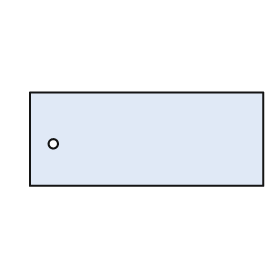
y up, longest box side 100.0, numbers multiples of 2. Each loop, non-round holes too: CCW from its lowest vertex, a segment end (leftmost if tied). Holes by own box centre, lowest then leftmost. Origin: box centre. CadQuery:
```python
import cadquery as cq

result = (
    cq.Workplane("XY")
    .moveTo(-50.0, -20.0)
    .lineTo(50.0, -20.0)
    .lineTo(50.0, 20.0)
    .lineTo(-50.0, 20.0)
    .close()
    .moveTo(-40.0, -2.0)
    .circle(2.0)
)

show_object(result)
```